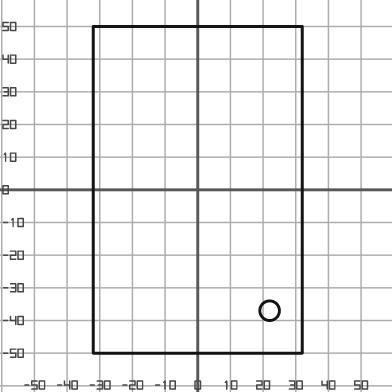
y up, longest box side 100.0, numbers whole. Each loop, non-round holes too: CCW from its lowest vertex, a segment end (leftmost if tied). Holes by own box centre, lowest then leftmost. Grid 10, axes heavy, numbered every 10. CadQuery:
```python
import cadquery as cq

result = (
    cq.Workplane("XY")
    .moveTo(-32.0, -50.0)
    .lineTo(32.0, -50.0)
    .lineTo(32.0, 50.0)
    .lineTo(-32.0, 50.0)
    .close()
    .moveTo(22.0, -37.0)
    .circle(3.0)
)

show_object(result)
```